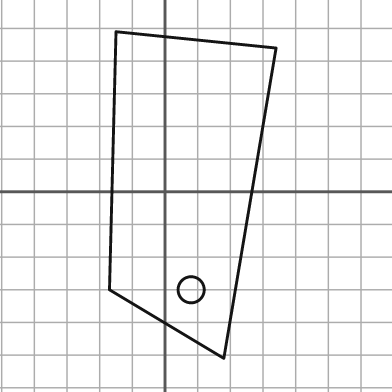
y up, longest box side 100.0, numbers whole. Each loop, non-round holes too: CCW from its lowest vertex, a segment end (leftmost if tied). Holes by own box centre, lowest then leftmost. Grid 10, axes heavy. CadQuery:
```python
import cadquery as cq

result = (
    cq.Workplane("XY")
    .moveTo(18.0, -51.0)
    .lineTo(34.0, 44.0)
    .lineTo(-15.0, 49.0)
    .lineTo(-17.0, -30.0)
    .close()
    .moveTo(8.0, -30.0)
    .circle(4.0)
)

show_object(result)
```